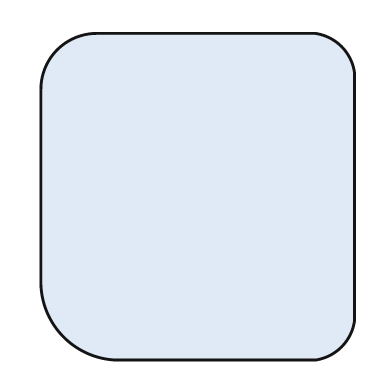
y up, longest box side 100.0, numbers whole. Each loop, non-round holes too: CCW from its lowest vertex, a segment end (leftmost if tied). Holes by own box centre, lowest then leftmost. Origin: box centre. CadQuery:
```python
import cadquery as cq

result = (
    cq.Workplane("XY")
    .moveTo(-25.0, -50.0)
    .lineTo(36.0, -50.0)
    .threePointArc((44.0, -46.0), (48.0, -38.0))
    .lineTo(48.0, 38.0)
    .threePointArc((44.0, 46.0), (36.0, 50.0))
    .lineTo(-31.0, 50.0)
    .threePointArc((-43.0, 45.0), (-48.0, 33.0))
    .lineTo(-48.0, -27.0)
    .threePointArc((-41.0, -43.0), (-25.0, -50.0))
    .close()
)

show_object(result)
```